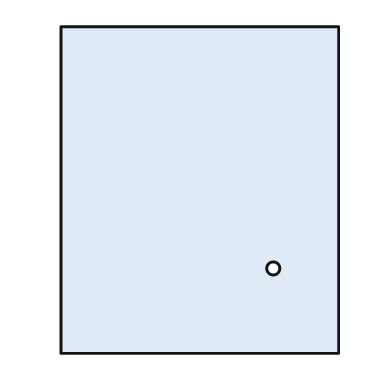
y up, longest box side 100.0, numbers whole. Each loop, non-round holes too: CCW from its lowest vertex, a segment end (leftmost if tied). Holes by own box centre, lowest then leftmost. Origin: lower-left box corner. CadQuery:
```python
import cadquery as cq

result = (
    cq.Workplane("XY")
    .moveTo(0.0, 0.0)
    .lineTo(85.0, 0.0)
    .lineTo(85.0, 100.0)
    .lineTo(0.0, 100.0)
    .close()
    .moveTo(65.0, 26.0)
    .circle(2.0)
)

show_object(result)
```